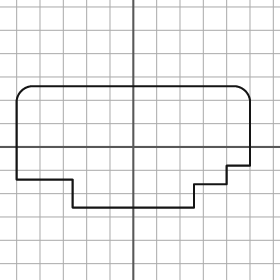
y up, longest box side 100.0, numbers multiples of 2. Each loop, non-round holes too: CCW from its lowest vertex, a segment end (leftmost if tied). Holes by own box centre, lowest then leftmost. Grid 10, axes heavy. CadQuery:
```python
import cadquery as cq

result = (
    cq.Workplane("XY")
    .moveTo(-26.0, -26.0)
    .lineTo(26.0, -26.0)
    .lineTo(26.0, -16.0)
    .lineTo(40.0, -16.0)
    .lineTo(40.0, -8.0)
    .lineTo(50.0, -8.0)
    .lineTo(50.0, 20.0)
    .threePointArc((48.0, 24.0), (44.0, 26.0))
    .lineTo(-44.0, 26.0)
    .threePointArc((-48.0, 24.0), (-50.0, 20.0))
    .lineTo(-50.0, -14.0)
    .lineTo(-26.0, -14.0)
    .close()
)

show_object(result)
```